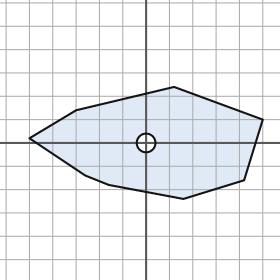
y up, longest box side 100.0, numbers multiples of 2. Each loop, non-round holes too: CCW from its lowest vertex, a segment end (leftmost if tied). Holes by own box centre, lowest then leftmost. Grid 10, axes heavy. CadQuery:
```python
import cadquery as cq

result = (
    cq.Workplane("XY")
    .moveTo(16.0, -24.0)
    .lineTo(42.0, -16.0)
    .lineTo(50.0, 10.0)
    .lineTo(12.0, 24.0)
    .lineTo(-30.0, 14.0)
    .lineTo(-50.0, 2.0)
    .lineTo(-26.0, -14.0)
    .lineTo(-16.0, -18.0)
    .close()
    .moveTo(0.0, 0.0)
    .circle(4.0)
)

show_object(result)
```